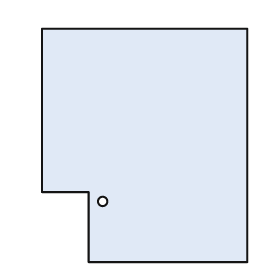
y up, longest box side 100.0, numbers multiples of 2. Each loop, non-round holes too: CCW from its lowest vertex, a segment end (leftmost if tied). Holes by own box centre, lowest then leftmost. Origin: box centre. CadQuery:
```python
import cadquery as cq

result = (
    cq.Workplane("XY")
    .moveTo(-24.0, -50.0)
    .lineTo(44.0, -50.0)
    .lineTo(44.0, 50.0)
    .lineTo(-44.0, 50.0)
    .lineTo(-44.0, -20.0)
    .lineTo(-24.0, -20.0)
    .close()
    .moveTo(-18.0, -24.0)
    .circle(2.0)
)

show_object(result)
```